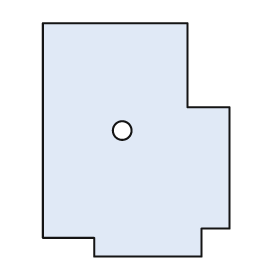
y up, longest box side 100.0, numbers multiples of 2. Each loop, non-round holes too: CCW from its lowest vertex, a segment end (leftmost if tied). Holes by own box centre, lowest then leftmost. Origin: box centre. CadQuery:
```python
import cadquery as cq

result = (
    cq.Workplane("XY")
    .moveTo(-18.0, -50.0)
    .lineTo(28.0, -50.0)
    .lineTo(28.0, -38.0)
    .lineTo(40.0, -38.0)
    .lineTo(40.0, 14.0)
    .lineTo(22.0, 14.0)
    .lineTo(22.0, 50.0)
    .lineTo(-40.0, 50.0)
    .lineTo(-40.0, -42.0)
    .lineTo(-18.0, -42.0)
    .close()
    .moveTo(-6.0, 4.0)
    .circle(4.0)
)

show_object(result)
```